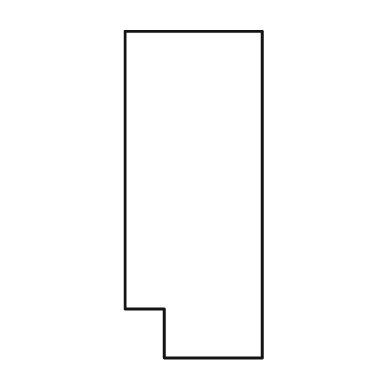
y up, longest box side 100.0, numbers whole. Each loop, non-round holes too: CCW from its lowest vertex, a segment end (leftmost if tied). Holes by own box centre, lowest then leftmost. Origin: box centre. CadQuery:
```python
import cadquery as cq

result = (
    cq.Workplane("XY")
    .moveTo(-9.0, -50.0)
    .lineTo(21.0, -50.0)
    .lineTo(21.0, 50.0)
    .lineTo(-21.0, 50.0)
    .lineTo(-21.0, -35.0)
    .lineTo(-9.0, -35.0)
    .close()
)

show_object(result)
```